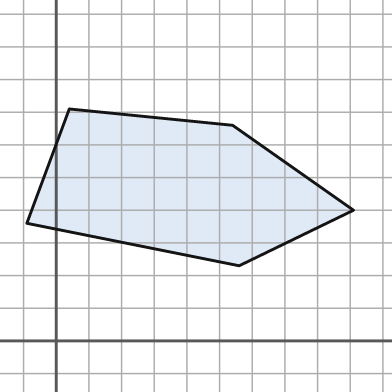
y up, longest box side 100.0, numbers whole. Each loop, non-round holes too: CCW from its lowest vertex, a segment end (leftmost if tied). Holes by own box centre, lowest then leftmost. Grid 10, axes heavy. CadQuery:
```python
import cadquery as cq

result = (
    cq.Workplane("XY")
    .moveTo(56.0, 23.0)
    .lineTo(91.0, 40.0)
    .lineTo(54.0, 66.0)
    .lineTo(4.0, 71.0)
    .lineTo(-9.0, 36.0)
    .close()
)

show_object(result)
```